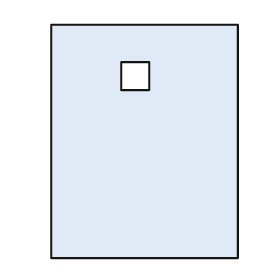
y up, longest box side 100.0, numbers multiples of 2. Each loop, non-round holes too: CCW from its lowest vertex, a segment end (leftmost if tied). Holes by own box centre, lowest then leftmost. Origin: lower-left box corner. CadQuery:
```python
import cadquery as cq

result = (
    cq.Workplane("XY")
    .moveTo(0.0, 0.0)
    .lineTo(80.0, 0.0)
    .lineTo(80.0, 100.0)
    .lineTo(0.0, 100.0)
    .close()
    .moveTo(30.0, 72.0)
    .lineTo(42.0, 72.0)
    .lineTo(42.0, 84.0)
    .lineTo(30.0, 84.0)
    .close()
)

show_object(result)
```